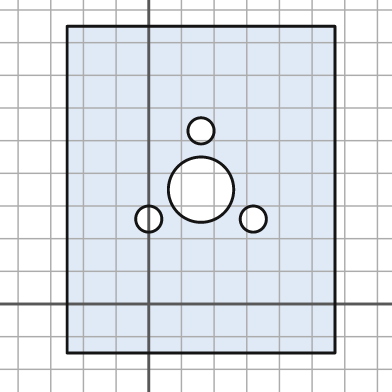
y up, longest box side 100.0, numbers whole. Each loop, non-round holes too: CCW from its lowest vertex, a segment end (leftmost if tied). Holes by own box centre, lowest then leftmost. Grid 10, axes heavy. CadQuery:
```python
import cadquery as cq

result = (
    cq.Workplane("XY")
    .moveTo(-25.0, -15.0)
    .lineTo(57.0, -15.0)
    .lineTo(57.0, 85.0)
    .lineTo(-25.0, 85.0)
    .close()
    .moveTo(0.0, 26.0)
    .circle(4.0)
    .moveTo(32.0, 26.0)
    .circle(4.0)
    .moveTo(16.0, 35.0)
    .circle(10.0)
    .moveTo(16.0, 53.0)
    .circle(4.0)
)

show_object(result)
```